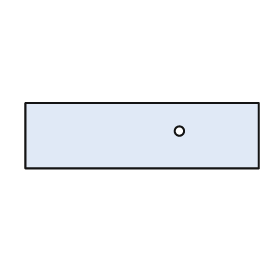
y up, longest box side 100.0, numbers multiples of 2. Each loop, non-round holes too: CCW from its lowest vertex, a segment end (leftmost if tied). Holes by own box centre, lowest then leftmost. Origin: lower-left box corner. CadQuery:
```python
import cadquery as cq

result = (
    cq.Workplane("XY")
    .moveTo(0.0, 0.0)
    .lineTo(100.0, 0.0)
    .lineTo(100.0, 28.0)
    .lineTo(0.0, 28.0)
    .close()
    .moveTo(66.0, 16.0)
    .circle(2.0)
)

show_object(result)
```